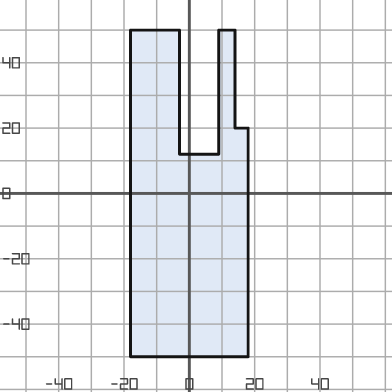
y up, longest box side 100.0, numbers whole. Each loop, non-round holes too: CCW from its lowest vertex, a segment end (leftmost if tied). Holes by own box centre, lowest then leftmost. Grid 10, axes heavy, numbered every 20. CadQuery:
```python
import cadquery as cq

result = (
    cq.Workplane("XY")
    .moveTo(-18.0, -50.0)
    .lineTo(18.0, -50.0)
    .lineTo(18.0, 20.0)
    .lineTo(14.0, 20.0)
    .lineTo(14.0, 50.0)
    .lineTo(9.0, 50.0)
    .lineTo(9.0, 12.0)
    .lineTo(-3.0, 12.0)
    .lineTo(-3.0, 50.0)
    .lineTo(-18.0, 50.0)
    .close()
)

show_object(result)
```